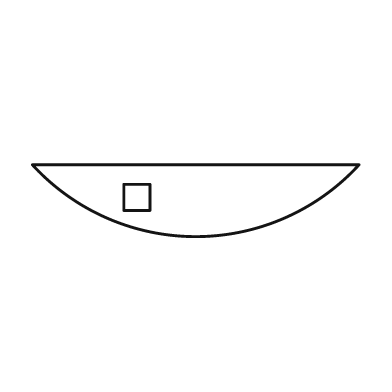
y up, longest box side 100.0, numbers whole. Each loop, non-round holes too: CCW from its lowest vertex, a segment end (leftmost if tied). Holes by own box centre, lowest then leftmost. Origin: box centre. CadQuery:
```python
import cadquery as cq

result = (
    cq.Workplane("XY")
    .moveTo(-50.0, 11.0)
    .threePointArc((0.0, -11.0), (50.0, 11.0))
    .close()
    .moveTo(-22.0, -3.0)
    .lineTo(-14.0, -3.0)
    .lineTo(-14.0, 5.0)
    .lineTo(-22.0, 5.0)
    .close()
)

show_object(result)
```